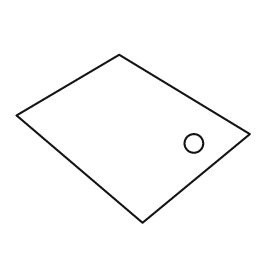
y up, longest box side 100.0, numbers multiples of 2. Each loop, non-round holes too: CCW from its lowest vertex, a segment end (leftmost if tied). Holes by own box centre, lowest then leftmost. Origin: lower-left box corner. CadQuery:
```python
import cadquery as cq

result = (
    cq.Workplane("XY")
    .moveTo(54.0, 0.0)
    .lineTo(100.0, 38.0)
    .lineTo(44.0, 72.0)
    .lineTo(0.0, 46.0)
    .close()
    .moveTo(76.0, 34.0)
    .circle(4.0)
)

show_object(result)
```